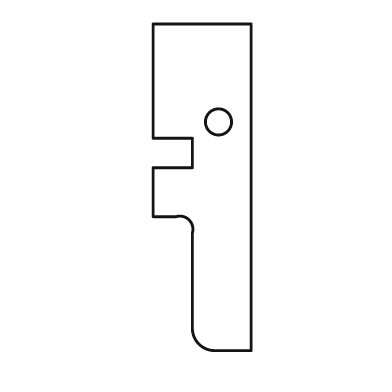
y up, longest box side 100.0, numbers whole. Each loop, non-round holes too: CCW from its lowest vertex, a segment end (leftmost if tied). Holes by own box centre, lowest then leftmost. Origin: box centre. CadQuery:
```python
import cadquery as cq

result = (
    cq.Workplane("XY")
    .moveTo(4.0, -50.0)
    .lineTo(15.0, -50.0)
    .lineTo(15.0, 50.0)
    .lineTo(-15.0, 50.0)
    .lineTo(-15.0, 15.0)
    .lineTo(-3.0, 15.0)
    .lineTo(-3.0, 6.0)
    .lineTo(-15.0, 6.0)
    .lineTo(-15.0, -9.0)
    .lineTo(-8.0, -9.0)
    .threePointArc((-4.0, -10.0), (-3.0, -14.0))
    .lineTo(-3.0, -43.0)
    .threePointArc((-1.0, -48.0), (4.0, -50.0))
    .close()
    .moveTo(5.0, 20.0)
    .circle(4.0)
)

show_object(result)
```